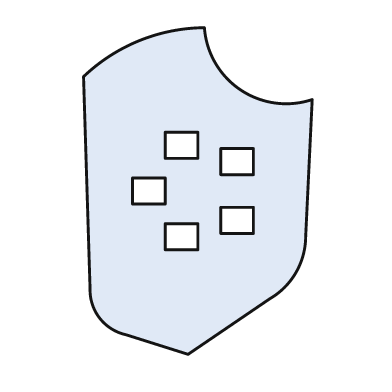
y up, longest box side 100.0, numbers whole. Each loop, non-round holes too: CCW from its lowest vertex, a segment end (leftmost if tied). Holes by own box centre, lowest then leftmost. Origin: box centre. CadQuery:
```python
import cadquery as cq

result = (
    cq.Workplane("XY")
    .moveTo(-3.0, -50.0)
    .lineTo(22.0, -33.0)
    .threePointArc((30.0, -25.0), (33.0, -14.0))
    .lineTo(35.0, 28.0)
    .threePointArc((13.0, 31.0), (2.0, 50.0))
    .threePointArc((-18.0, 46.0), (-35.0, 35.0))
    .lineTo(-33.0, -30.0)
    .threePointArc((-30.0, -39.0), (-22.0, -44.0))
    .close()
    .moveTo(-10.0, -18.0)
    .lineTo(0.0, -18.0)
    .lineTo(0.0, -10.0)
    .lineTo(-10.0, -10.0)
    .close()
    .moveTo(7.0, -13.0)
    .lineTo(17.0, -13.0)
    .lineTo(17.0, -5.0)
    .lineTo(7.0, -5.0)
    .close()
    .moveTo(-20.0, -4.0)
    .lineTo(-10.0, -4.0)
    .lineTo(-10.0, 4.0)
    .lineTo(-20.0, 4.0)
    .close()
    .moveTo(7.0, 5.0)
    .lineTo(17.0, 5.0)
    .lineTo(17.0, 13.0)
    .lineTo(7.0, 13.0)
    .close()
    .moveTo(-10.0, 10.0)
    .lineTo(0.0, 10.0)
    .lineTo(0.0, 18.0)
    .lineTo(-10.0, 18.0)
    .close()
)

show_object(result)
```